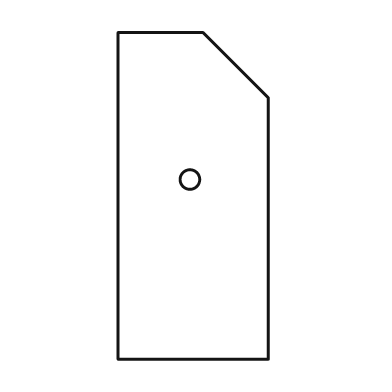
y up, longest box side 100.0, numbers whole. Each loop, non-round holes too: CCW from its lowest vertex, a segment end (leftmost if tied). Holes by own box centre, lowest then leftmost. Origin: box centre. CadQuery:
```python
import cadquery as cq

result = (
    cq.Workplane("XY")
    .moveTo(-23.0, -50.0)
    .lineTo(23.0, -50.0)
    .lineTo(23.0, 30.0)
    .lineTo(3.0, 50.0)
    .lineTo(-23.0, 50.0)
    .close()
    .moveTo(-1.0, 5.0)
    .circle(3.0)
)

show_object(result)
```